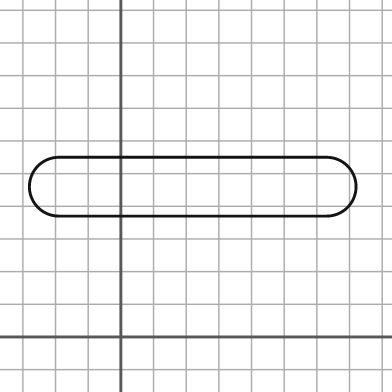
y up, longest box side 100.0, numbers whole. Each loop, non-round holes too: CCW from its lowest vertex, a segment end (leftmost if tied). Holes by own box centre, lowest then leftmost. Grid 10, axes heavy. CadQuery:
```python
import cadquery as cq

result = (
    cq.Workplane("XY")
    .moveTo(-19.0, 37.0)
    .lineTo(63.0, 37.0)
    .threePointArc((72.0, 46.0), (63.0, 55.0))
    .lineTo(-19.0, 55.0)
    .threePointArc((-28.0, 46.0), (-19.0, 37.0))
    .close()
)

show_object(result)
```